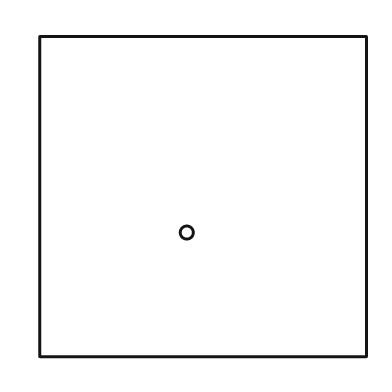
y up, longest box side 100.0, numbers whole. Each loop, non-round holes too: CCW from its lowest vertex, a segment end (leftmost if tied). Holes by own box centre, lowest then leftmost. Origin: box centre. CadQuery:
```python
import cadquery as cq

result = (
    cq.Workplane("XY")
    .moveTo(-50.0, -49.0)
    .lineTo(50.0, -49.0)
    .lineTo(50.0, 49.0)
    .lineTo(-50.0, 49.0)
    .close()
    .moveTo(-5.0, -11.0)
    .circle(2.0)
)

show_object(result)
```